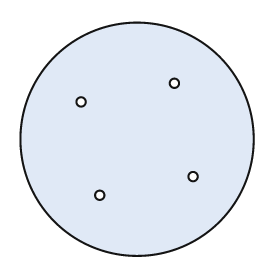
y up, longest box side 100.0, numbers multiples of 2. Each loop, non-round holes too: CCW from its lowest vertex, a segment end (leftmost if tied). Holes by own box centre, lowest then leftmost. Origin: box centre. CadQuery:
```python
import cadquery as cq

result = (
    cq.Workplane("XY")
    .moveTo(0.0, 0.0)
    .circle(50.0)
    .moveTo(-16.0, -24.0)
    .circle(2.0)
    .moveTo(24.0, -16.0)
    .circle(2.0)
    .moveTo(-24.0, 16.0)
    .circle(2.0)
    .moveTo(16.0, 24.0)
    .circle(2.0)
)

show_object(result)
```